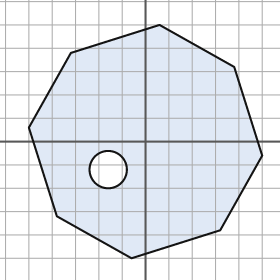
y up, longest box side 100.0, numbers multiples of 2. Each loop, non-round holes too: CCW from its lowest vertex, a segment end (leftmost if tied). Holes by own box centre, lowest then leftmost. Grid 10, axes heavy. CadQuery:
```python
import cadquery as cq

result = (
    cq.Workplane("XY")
    .moveTo(-6.0, -50.0)
    .lineTo(32.0, -38.0)
    .lineTo(50.0, -6.0)
    .lineTo(38.0, 32.0)
    .lineTo(6.0, 50.0)
    .lineTo(-32.0, 38.0)
    .lineTo(-50.0, 6.0)
    .lineTo(-38.0, -32.0)
    .close()
    .moveTo(-16.0, -12.0)
    .circle(8.0)
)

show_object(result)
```